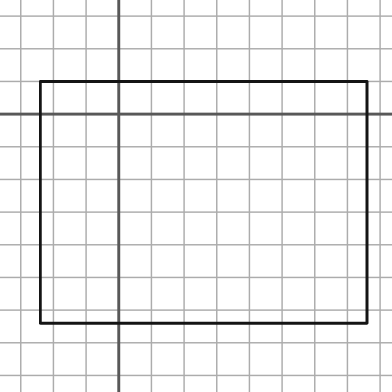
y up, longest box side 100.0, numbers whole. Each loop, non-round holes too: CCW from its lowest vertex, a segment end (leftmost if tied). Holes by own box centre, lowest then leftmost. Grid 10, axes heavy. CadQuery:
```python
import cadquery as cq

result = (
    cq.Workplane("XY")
    .moveTo(-24.0, -64.0)
    .lineTo(76.0, -64.0)
    .lineTo(76.0, 10.0)
    .lineTo(-24.0, 10.0)
    .close()
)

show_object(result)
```